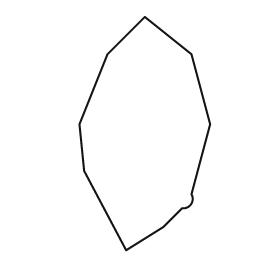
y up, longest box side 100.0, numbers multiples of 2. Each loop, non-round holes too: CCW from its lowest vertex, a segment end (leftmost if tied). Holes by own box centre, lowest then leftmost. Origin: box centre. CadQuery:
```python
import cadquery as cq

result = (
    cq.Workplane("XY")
    .moveTo(-8.0, -50.0)
    .lineTo(8.0, -40.0)
    .lineTo(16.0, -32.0)
    .threePointArc((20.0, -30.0), (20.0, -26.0))
    .lineTo(28.0, 4.0)
    .lineTo(20.0, 34.0)
    .lineTo(0.0, 50.0)
    .lineTo(-16.0, 34.0)
    .lineTo(-28.0, 4.0)
    .lineTo(-26.0, -16.0)
    .close()
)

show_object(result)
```